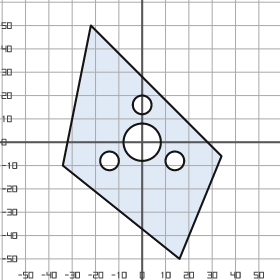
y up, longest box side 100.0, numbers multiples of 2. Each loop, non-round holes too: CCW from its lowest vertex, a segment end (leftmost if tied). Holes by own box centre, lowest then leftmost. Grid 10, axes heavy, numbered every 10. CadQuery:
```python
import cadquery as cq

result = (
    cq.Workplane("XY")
    .moveTo(16.0, -50.0)
    .lineTo(34.0, -6.0)
    .lineTo(-22.0, 50.0)
    .lineTo(-34.0, -10.0)
    .close()
    .moveTo(-14.0, -8.0)
    .circle(4.0)
    .moveTo(14.0, -8.0)
    .circle(4.0)
    .moveTo(0.0, 0.0)
    .circle(8.0)
    .moveTo(0.0, 16.0)
    .circle(4.0)
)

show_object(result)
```